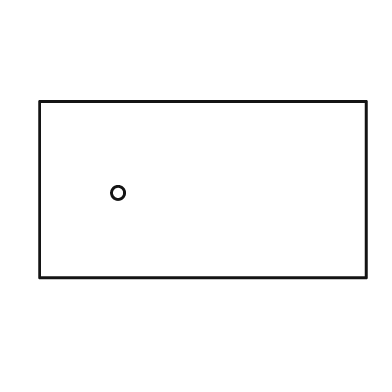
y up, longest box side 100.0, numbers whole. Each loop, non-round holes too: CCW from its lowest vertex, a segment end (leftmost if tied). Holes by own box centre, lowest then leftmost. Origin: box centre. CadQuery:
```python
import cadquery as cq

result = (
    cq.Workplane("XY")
    .moveTo(-50.0, -27.0)
    .lineTo(50.0, -27.0)
    .lineTo(50.0, 27.0)
    .lineTo(-50.0, 27.0)
    .close()
    .moveTo(-26.0, -1.0)
    .circle(2.0)
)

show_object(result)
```